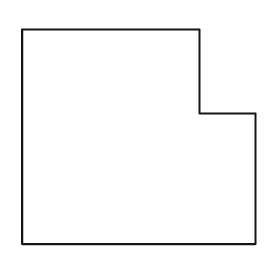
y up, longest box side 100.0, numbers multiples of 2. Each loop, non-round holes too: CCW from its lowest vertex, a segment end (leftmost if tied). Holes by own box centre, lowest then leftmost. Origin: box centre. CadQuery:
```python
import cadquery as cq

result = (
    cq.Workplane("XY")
    .moveTo(-50.0, -46.0)
    .lineTo(50.0, -46.0)
    .lineTo(50.0, 10.0)
    .lineTo(26.0, 10.0)
    .lineTo(26.0, 46.0)
    .lineTo(-50.0, 46.0)
    .close()
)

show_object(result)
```